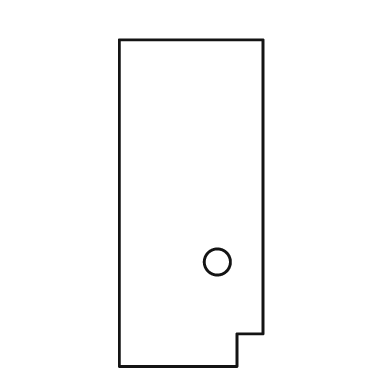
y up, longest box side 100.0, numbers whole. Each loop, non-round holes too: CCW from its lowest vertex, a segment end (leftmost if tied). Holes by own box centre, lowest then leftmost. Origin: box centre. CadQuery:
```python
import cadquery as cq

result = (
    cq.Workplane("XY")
    .moveTo(-22.0, -50.0)
    .lineTo(14.0, -50.0)
    .lineTo(14.0, -40.0)
    .lineTo(22.0, -40.0)
    .lineTo(22.0, 50.0)
    .lineTo(-22.0, 50.0)
    .close()
    .moveTo(8.0, -18.0)
    .circle(4.0)
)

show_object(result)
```